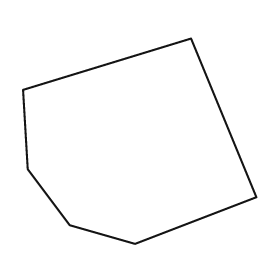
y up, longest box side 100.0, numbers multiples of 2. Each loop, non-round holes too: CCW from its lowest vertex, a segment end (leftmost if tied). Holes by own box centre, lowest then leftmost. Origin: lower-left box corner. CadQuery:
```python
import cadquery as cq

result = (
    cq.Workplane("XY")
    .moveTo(48.0, 0.0)
    .lineTo(100.0, 20.0)
    .lineTo(72.0, 88.0)
    .lineTo(0.0, 66.0)
    .lineTo(2.0, 32.0)
    .lineTo(20.0, 8.0)
    .close()
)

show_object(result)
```